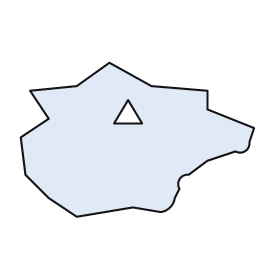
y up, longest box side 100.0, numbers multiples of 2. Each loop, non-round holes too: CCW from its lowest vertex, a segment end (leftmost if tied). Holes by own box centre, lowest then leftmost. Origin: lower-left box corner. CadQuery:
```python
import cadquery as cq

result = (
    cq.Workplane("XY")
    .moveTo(24.0, 0.0)
    .lineTo(48.0, 4.0)
    .lineTo(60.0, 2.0)
    .threePointArc((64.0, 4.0), (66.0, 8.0))
    .lineTo(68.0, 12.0)
    .threePointArc((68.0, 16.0), (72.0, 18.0))
    .lineTo(80.0, 24.0)
    .lineTo(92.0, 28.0)
    .threePointArc((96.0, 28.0), (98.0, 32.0))
    .lineTo(100.0, 38.0)
    .lineTo(80.0, 46.0)
    .lineTo(80.0, 54.0)
    .lineTo(56.0, 56.0)
    .lineTo(38.0, 66.0)
    .lineTo(24.0, 56.0)
    .lineTo(4.0, 54.0)
    .lineTo(12.0, 42.0)
    .lineTo(0.0, 34.0)
    .lineTo(2.0, 18.0)
    .lineTo(12.0, 8.0)
    .close()
    .moveTo(40.0, 40.0)
    .lineTo(52.0, 40.0)
    .lineTo(46.0, 50.0)
    .close()
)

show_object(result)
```